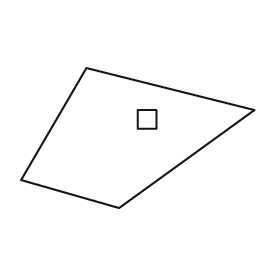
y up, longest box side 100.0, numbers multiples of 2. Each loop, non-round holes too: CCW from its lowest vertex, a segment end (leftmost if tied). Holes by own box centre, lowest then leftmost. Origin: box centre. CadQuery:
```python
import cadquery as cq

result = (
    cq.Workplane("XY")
    .moveTo(-8.0, -30.0)
    .lineTo(50.0, 12.0)
    .lineTo(-22.0, 30.0)
    .lineTo(-50.0, -18.0)
    .close()
    .moveTo(0.0, 4.0)
    .lineTo(8.0, 4.0)
    .lineTo(8.0, 12.0)
    .lineTo(0.0, 12.0)
    .close()
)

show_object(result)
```